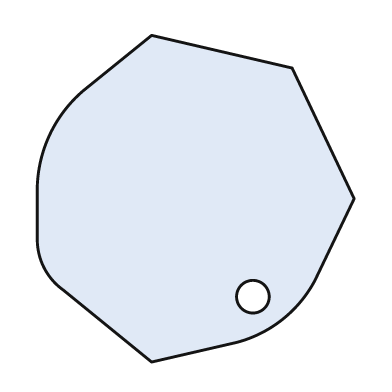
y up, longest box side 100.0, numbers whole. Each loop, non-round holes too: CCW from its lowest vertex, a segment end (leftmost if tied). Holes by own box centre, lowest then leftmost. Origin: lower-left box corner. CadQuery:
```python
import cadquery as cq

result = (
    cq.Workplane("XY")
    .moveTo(35.0, 0.0)
    .lineTo(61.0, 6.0)
    .threePointArc((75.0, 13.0), (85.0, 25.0))
    .lineTo(97.0, 50.0)
    .lineTo(78.0, 90.0)
    .lineTo(35.0, 100.0)
    .lineTo(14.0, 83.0)
    .threePointArc((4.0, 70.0), (0.0, 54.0))
    .lineTo(0.0, 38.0)
    .threePointArc((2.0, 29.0), (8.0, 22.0))
    .close()
    .moveTo(66.0, 20.0)
    .circle(5.0)
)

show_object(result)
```